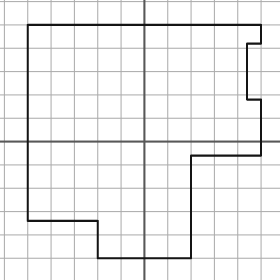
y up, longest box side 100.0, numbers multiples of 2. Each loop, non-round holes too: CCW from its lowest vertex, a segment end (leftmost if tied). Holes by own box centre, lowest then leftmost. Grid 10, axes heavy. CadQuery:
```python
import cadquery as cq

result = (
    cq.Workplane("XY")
    .moveTo(-20.0, -50.0)
    .lineTo(20.0, -50.0)
    .lineTo(20.0, -6.0)
    .lineTo(50.0, -6.0)
    .lineTo(50.0, 18.0)
    .lineTo(44.0, 18.0)
    .lineTo(44.0, 42.0)
    .lineTo(50.0, 42.0)
    .lineTo(50.0, 50.0)
    .lineTo(-50.0, 50.0)
    .lineTo(-50.0, -34.0)
    .lineTo(-20.0, -34.0)
    .close()
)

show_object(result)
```